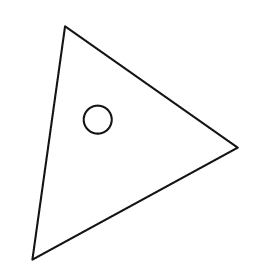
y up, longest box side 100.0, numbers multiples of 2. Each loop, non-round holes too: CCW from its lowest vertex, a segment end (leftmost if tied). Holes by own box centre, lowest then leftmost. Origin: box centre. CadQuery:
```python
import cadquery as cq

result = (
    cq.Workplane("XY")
    .moveTo(-44.0, -50.0)
    .lineTo(44.0, -2.0)
    .lineTo(-30.0, 50.0)
    .close()
    .moveTo(-16.0, 10.0)
    .circle(6.0)
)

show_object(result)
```